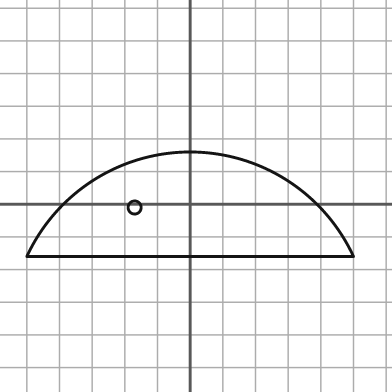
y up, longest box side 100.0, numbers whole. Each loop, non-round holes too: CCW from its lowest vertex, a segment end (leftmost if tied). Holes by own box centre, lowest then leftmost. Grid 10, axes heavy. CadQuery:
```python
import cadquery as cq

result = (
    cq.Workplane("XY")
    .moveTo(-50.0, -16.0)
    .lineTo(50.0, -16.0)
    .threePointArc((0.0, 16.0), (-50.0, -16.0))
    .close()
    .moveTo(-17.0, -1.0)
    .circle(2.0)
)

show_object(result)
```